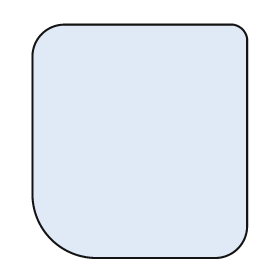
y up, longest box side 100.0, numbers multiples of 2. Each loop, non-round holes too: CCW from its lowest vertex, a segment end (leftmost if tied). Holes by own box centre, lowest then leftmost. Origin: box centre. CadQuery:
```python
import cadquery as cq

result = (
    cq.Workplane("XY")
    .moveTo(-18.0, -50.0)
    .lineTo(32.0, -50.0)
    .threePointArc((42.0, -46.0), (46.0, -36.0))
    .lineTo(46.0, 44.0)
    .threePointArc((44.0, 48.0), (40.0, 50.0))
    .lineTo(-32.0, 50.0)
    .threePointArc((-42.0, 46.0), (-46.0, 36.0))
    .lineTo(-46.0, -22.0)
    .threePointArc((-38.0, -42.0), (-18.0, -50.0))
    .close()
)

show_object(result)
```